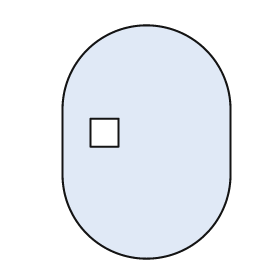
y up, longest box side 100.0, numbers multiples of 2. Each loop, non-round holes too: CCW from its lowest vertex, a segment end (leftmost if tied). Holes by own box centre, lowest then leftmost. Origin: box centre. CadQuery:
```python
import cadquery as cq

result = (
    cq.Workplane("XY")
    .moveTo(-36.0, -14.0)
    .threePointArc((0.0, -50.0), (36.0, -14.0))
    .lineTo(36.0, 14.0)
    .threePointArc((0.0, 50.0), (-36.0, 14.0))
    .close()
    .moveTo(-24.0, -2.0)
    .lineTo(-12.0, -2.0)
    .lineTo(-12.0, 10.0)
    .lineTo(-24.0, 10.0)
    .close()
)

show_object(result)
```